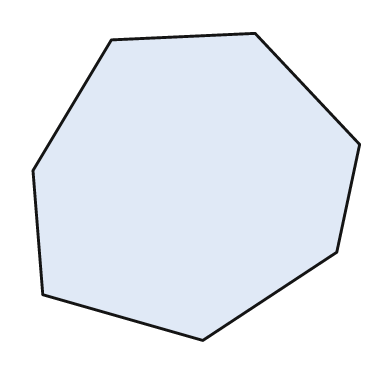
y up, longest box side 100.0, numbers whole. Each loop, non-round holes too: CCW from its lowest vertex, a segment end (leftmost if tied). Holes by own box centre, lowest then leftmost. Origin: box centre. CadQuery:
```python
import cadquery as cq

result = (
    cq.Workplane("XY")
    .moveTo(2.0, -47.0)
    .lineTo(43.0, -20.0)
    .lineTo(50.0, 13.0)
    .lineTo(18.0, 47.0)
    .lineTo(-26.0, 45.0)
    .lineTo(-50.0, 5.0)
    .lineTo(-47.0, -33.0)
    .close()
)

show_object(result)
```